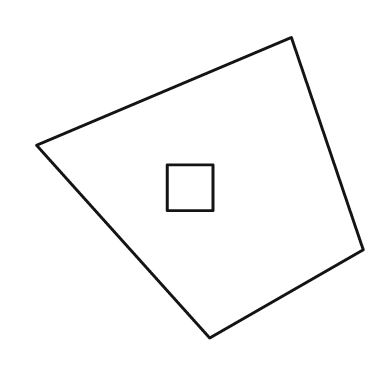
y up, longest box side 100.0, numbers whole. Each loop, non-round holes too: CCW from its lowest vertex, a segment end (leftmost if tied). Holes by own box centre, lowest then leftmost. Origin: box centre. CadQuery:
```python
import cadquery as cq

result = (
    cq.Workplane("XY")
    .moveTo(3.0, -46.0)
    .lineTo(50.0, -19.0)
    .lineTo(28.0, 46.0)
    .lineTo(-50.0, 13.0)
    .close()
    .moveTo(-10.0, -7.0)
    .lineTo(4.0, -7.0)
    .lineTo(4.0, 7.0)
    .lineTo(-10.0, 7.0)
    .close()
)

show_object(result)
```